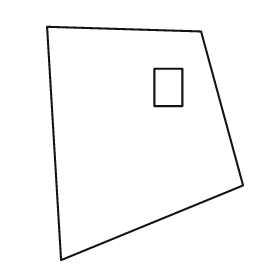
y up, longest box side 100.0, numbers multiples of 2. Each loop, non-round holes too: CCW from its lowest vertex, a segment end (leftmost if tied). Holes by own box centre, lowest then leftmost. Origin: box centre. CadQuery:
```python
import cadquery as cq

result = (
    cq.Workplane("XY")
    .moveTo(-36.0, -50.0)
    .lineTo(42.0, -18.0)
    .lineTo(24.0, 48.0)
    .lineTo(-42.0, 50.0)
    .close()
    .moveTo(4.0, 16.0)
    .lineTo(16.0, 16.0)
    .lineTo(16.0, 32.0)
    .lineTo(4.0, 32.0)
    .close()
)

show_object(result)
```